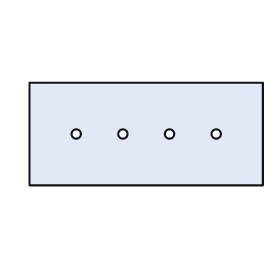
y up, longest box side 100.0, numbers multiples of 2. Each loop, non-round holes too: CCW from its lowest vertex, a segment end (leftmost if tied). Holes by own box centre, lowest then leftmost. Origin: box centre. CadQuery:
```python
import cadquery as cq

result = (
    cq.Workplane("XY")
    .moveTo(-50.0, -22.0)
    .lineTo(50.0, -22.0)
    .lineTo(50.0, 22.0)
    .lineTo(-50.0, 22.0)
    .close()
    .moveTo(-30.0, 0.0)
    .circle(2.0)
    .moveTo(-10.0, 0.0)
    .circle(2.0)
    .moveTo(10.0, 0.0)
    .circle(2.0)
    .moveTo(30.0, 0.0)
    .circle(2.0)
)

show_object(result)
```